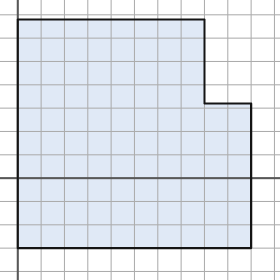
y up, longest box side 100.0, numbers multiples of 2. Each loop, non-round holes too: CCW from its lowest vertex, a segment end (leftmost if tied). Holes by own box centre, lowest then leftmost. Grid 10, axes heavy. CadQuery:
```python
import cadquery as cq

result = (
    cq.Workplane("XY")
    .moveTo(0.0, -30.0)
    .lineTo(100.0, -30.0)
    .lineTo(100.0, 32.0)
    .lineTo(80.0, 32.0)
    .lineTo(80.0, 68.0)
    .lineTo(0.0, 68.0)
    .close()
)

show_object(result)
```